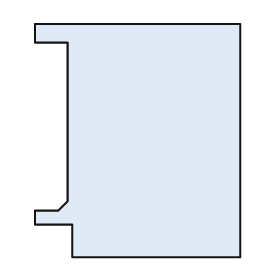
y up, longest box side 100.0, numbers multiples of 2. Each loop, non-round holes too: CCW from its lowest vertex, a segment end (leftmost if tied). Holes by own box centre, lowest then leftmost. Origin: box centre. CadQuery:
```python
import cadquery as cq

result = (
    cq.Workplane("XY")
    .moveTo(-28.0, -50.0)
    .lineTo(44.0, -50.0)
    .lineTo(44.0, 50.0)
    .lineTo(-44.0, 50.0)
    .lineTo(-44.0, 42.0)
    .lineTo(-30.0, 42.0)
    .lineTo(-30.0, -26.0)
    .lineTo(-34.0, -30.0)
    .lineTo(-44.0, -30.0)
    .lineTo(-44.0, -36.0)
    .lineTo(-28.0, -36.0)
    .close()
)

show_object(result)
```